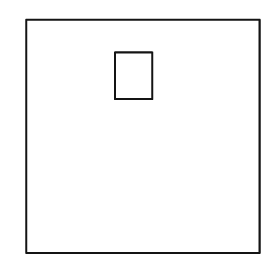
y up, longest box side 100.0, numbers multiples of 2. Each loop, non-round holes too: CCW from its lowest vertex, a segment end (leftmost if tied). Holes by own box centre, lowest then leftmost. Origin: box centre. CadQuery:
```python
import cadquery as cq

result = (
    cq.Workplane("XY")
    .moveTo(-50.0, -50.0)
    .lineTo(50.0, -50.0)
    .lineTo(50.0, 50.0)
    .lineTo(-50.0, 50.0)
    .close()
    .moveTo(-12.0, 16.0)
    .lineTo(4.0, 16.0)
    .lineTo(4.0, 36.0)
    .lineTo(-12.0, 36.0)
    .close()
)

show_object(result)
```